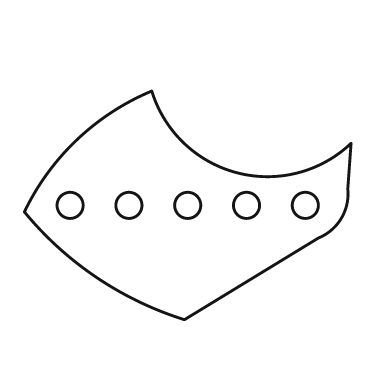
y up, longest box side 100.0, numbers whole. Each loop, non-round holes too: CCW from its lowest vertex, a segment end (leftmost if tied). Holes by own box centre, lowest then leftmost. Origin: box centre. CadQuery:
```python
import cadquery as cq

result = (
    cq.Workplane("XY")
    .moveTo(-1.0, -35.0)
    .lineTo(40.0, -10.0)
    .threePointArc((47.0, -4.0), (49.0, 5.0))
    .lineTo(50.0, 19.0)
    .threePointArc((15.0, 10.0), (-11.0, 35.0))
    .threePointArc((-34.0, 20.0), (-50.0, -2.0))
    .threePointArc((-28.0, -22.0), (-1.0, -35.0))
    .close()
    .moveTo(-36.0, 0.0)
    .circle(4.0)
    .moveTo(-18.0, 0.0)
    .circle(4.0)
    .moveTo(0.0, 0.0)
    .circle(4.0)
    .moveTo(18.0, 0.0)
    .circle(4.0)
    .moveTo(36.0, 0.0)
    .circle(4.0)
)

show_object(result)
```